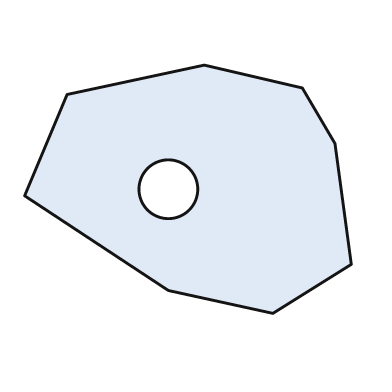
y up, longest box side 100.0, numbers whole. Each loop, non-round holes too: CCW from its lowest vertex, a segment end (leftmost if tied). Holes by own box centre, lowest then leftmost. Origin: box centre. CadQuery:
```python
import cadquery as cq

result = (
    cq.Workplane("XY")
    .moveTo(26.0, -38.0)
    .lineTo(50.0, -23.0)
    .lineTo(45.0, 14.0)
    .lineTo(35.0, 31.0)
    .lineTo(5.0, 38.0)
    .lineTo(-37.0, 29.0)
    .lineTo(-50.0, -2.0)
    .lineTo(-6.0, -31.0)
    .close()
    .moveTo(-6.0, 0.0)
    .circle(9.0)
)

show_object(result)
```